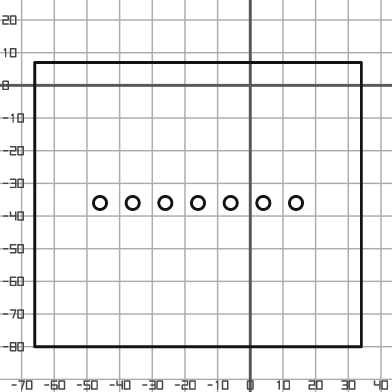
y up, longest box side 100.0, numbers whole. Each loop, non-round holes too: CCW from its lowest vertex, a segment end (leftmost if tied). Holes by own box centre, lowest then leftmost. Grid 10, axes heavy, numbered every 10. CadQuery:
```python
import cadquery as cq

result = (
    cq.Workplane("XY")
    .moveTo(-66.0, -80.0)
    .lineTo(34.0, -80.0)
    .lineTo(34.0, 7.0)
    .lineTo(-66.0, 7.0)
    .close()
    .moveTo(-46.0, -36.0)
    .circle(2.0)
    .moveTo(-36.0, -36.0)
    .circle(2.0)
    .moveTo(-26.0, -36.0)
    .circle(2.0)
    .moveTo(-16.0, -36.0)
    .circle(2.0)
    .moveTo(-6.0, -36.0)
    .circle(2.0)
    .moveTo(4.0, -36.0)
    .circle(2.0)
    .moveTo(14.0, -36.0)
    .circle(2.0)
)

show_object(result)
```